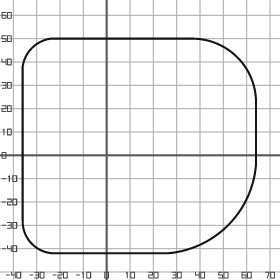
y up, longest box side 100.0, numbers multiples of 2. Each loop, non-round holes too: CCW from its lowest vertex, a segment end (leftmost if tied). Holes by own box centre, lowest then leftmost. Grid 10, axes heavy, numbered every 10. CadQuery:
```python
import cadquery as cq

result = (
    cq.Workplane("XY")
    .moveTo(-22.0, -42.0)
    .lineTo(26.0, -42.0)
    .threePointArc((52.0, -30.0), (64.0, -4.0))
    .lineTo(64.0, 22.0)
    .threePointArc((56.0, 42.0), (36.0, 50.0))
    .lineTo(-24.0, 50.0)
    .threePointArc((-32.0, 46.0), (-36.0, 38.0))
    .lineTo(-36.0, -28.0)
    .threePointArc((-32.0, -38.0), (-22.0, -42.0))
    .close()
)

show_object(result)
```